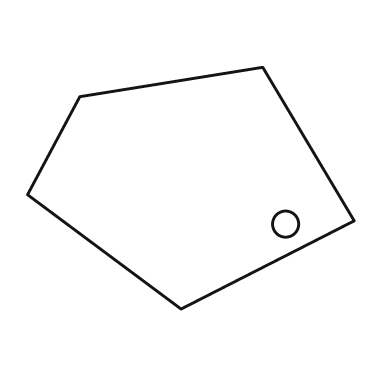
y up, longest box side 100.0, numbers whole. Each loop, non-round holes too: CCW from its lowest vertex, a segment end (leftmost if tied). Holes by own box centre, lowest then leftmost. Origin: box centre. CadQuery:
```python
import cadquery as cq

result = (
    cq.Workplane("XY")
    .moveTo(-3.0, -37.0)
    .lineTo(50.0, -10.0)
    .lineTo(22.0, 37.0)
    .lineTo(-34.0, 28.0)
    .lineTo(-50.0, -2.0)
    .close()
    .moveTo(29.0, -11.0)
    .circle(4.0)
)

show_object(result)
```